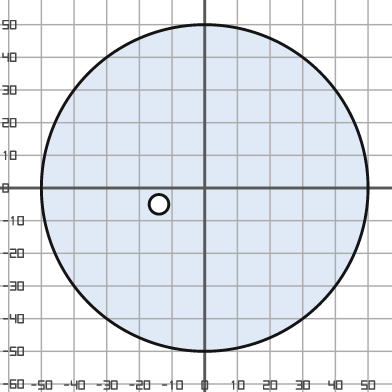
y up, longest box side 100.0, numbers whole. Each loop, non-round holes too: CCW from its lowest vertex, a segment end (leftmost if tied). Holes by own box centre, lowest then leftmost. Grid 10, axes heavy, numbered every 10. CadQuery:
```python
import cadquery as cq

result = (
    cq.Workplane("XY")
    .moveTo(0.0, 0.0)
    .circle(50.0)
    .moveTo(-14.0, -5.0)
    .circle(3.0)
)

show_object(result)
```